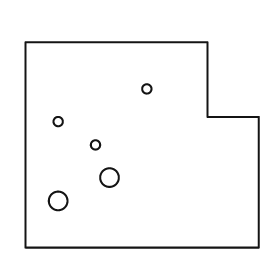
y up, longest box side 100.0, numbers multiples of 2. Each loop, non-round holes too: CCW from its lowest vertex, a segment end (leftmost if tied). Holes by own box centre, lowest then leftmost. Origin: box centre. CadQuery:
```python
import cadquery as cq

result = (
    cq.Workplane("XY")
    .moveTo(-50.0, -44.0)
    .lineTo(50.0, -44.0)
    .lineTo(50.0, 12.0)
    .lineTo(28.0, 12.0)
    .lineTo(28.0, 44.0)
    .lineTo(-50.0, 44.0)
    .close()
    .moveTo(-36.0, -24.0)
    .circle(4.0)
    .moveTo(-14.0, -14.0)
    .circle(4.0)
    .moveTo(-20.0, 0.0)
    .circle(2.0)
    .moveTo(-36.0, 10.0)
    .circle(2.0)
    .moveTo(2.0, 24.0)
    .circle(2.0)
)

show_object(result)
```